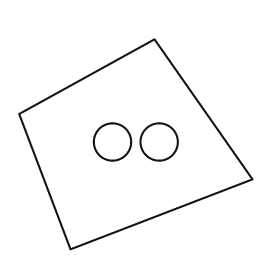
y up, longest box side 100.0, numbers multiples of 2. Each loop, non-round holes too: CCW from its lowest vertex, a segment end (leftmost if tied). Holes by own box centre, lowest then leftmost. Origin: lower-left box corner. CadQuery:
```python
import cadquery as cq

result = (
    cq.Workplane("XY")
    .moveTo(22.0, 0.0)
    .lineTo(100.0, 30.0)
    .lineTo(58.0, 90.0)
    .lineTo(0.0, 58.0)
    .close()
    .moveTo(40.0, 46.0)
    .circle(8.0)
    .moveTo(60.0, 46.0)
    .circle(8.0)
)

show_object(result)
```